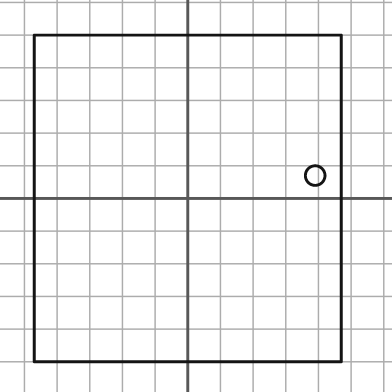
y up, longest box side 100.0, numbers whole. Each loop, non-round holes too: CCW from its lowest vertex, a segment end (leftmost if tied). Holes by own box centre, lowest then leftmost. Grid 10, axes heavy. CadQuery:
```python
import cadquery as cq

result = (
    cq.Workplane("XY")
    .moveTo(-47.0, -50.0)
    .lineTo(47.0, -50.0)
    .lineTo(47.0, 50.0)
    .lineTo(-47.0, 50.0)
    .close()
    .moveTo(39.0, 7.0)
    .circle(3.0)
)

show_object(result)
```